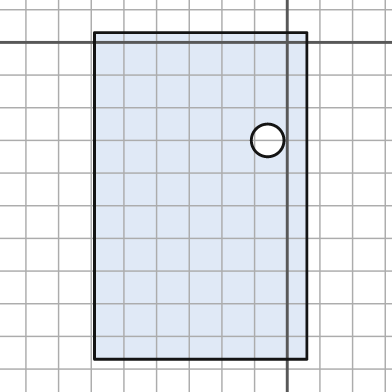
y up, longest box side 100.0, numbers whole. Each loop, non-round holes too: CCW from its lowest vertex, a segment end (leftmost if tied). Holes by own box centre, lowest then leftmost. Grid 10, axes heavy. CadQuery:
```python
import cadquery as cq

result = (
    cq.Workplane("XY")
    .moveTo(-59.0, -97.0)
    .lineTo(6.0, -97.0)
    .lineTo(6.0, 3.0)
    .lineTo(-59.0, 3.0)
    .close()
    .moveTo(-6.0, -30.0)
    .circle(5.0)
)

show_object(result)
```